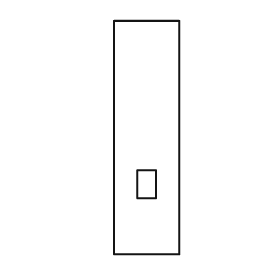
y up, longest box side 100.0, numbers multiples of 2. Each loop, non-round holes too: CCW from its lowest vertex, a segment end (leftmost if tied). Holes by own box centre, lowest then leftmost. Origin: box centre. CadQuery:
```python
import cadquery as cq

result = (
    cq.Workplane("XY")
    .moveTo(-14.0, -50.0)
    .lineTo(14.0, -50.0)
    .lineTo(14.0, 50.0)
    .lineTo(-14.0, 50.0)
    .close()
    .moveTo(-4.0, -26.0)
    .lineTo(4.0, -26.0)
    .lineTo(4.0, -14.0)
    .lineTo(-4.0, -14.0)
    .close()
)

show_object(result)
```